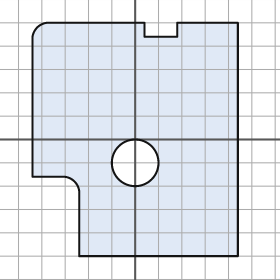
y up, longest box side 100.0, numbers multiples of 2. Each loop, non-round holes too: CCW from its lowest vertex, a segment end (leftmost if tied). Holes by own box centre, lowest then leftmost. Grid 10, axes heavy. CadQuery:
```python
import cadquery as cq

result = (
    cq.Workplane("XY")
    .moveTo(-24.0, -50.0)
    .lineTo(44.0, -50.0)
    .lineTo(44.0, 50.0)
    .lineTo(18.0, 50.0)
    .lineTo(18.0, 44.0)
    .lineTo(4.0, 44.0)
    .lineTo(4.0, 50.0)
    .lineTo(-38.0, 50.0)
    .threePointArc((-42.0, 48.0), (-44.0, 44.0))
    .lineTo(-44.0, -16.0)
    .lineTo(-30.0, -16.0)
    .threePointArc((-26.0, -18.0), (-24.0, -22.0))
    .close()
    .moveTo(0.0, -10.0)
    .circle(10.0)
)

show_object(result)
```